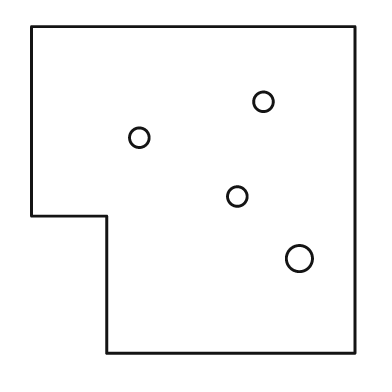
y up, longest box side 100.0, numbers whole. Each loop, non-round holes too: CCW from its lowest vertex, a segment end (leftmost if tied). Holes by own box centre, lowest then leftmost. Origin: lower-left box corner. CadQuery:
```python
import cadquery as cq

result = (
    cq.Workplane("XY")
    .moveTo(23.0, 0.0)
    .lineTo(99.0, 0.0)
    .lineTo(99.0, 100.0)
    .lineTo(0.0, 100.0)
    .lineTo(0.0, 42.0)
    .lineTo(23.0, 42.0)
    .close()
    .moveTo(82.0, 29.0)
    .circle(4.0)
    .moveTo(63.0, 48.0)
    .circle(3.0)
    .moveTo(33.0, 66.0)
    .circle(3.0)
    .moveTo(71.0, 77.0)
    .circle(3.0)
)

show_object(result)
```